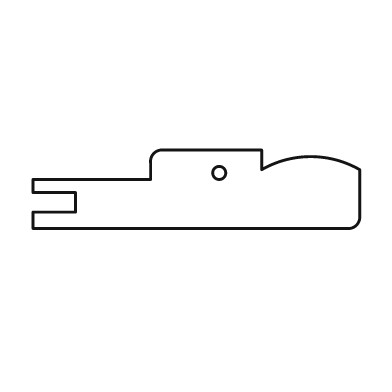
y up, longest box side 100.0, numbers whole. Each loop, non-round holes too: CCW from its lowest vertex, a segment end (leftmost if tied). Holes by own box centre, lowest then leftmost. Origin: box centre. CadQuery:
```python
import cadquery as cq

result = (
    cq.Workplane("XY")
    .moveTo(-50.0, -12.0)
    .lineTo(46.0, -12.0)
    .threePointArc((49.0, -11.0), (50.0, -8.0))
    .lineTo(50.0, 6.0)
    .threePointArc((35.0, 10.0), (20.0, 6.0))
    .lineTo(20.0, 12.0)
    .lineTo(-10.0, 12.0)
    .threePointArc((-13.0, 11.0), (-14.0, 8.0))
    .lineTo(-14.0, 3.0)
    .lineTo(-50.0, 3.0)
    .lineTo(-50.0, -1.0)
    .lineTo(-37.0, -1.0)
    .lineTo(-37.0, -7.0)
    .lineTo(-50.0, -7.0)
    .close()
    .moveTo(7.0, 5.0)
    .circle(2.0)
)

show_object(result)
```